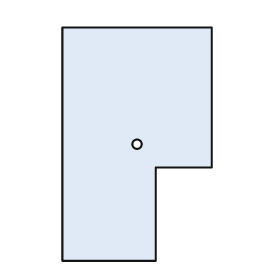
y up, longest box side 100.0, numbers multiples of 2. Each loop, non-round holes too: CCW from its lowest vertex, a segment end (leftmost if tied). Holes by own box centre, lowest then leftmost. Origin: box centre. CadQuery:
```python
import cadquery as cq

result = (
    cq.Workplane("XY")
    .moveTo(-32.0, -50.0)
    .lineTo(8.0, -50.0)
    .lineTo(8.0, -10.0)
    .lineTo(32.0, -10.0)
    .lineTo(32.0, 50.0)
    .lineTo(-32.0, 50.0)
    .close()
    .moveTo(0.0, 0.0)
    .circle(2.0)
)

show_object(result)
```